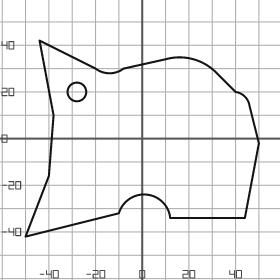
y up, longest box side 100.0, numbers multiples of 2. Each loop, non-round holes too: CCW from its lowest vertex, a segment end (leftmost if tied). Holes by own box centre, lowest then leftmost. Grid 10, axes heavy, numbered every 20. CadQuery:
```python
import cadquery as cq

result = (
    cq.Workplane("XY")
    .moveTo(-50.0, -42.0)
    .lineTo(-10.0, -32.0)
    .threePointArc((2.0, -24.0), (12.0, -34.0))
    .lineTo(44.0, -34.0)
    .lineTo(50.0, -2.0)
    .lineTo(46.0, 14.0)
    .threePointArc((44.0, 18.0), (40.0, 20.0))
    .lineTo(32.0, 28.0)
    .threePointArc((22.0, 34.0), (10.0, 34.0))
    .lineTo(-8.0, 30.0)
    .threePointArc((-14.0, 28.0), (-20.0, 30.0))
    .lineTo(-44.0, 42.0)
    .lineTo(-38.0, 10.0)
    .lineTo(-40.0, -16.0)
    .close()
    .moveTo(-28.0, 20.0)
    .circle(4.0)
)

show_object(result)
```